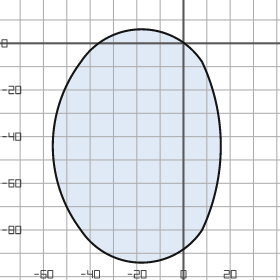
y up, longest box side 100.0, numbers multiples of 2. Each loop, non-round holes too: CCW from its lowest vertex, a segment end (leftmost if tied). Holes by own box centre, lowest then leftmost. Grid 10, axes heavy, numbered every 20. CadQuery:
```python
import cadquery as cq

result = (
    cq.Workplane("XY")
    .moveTo(-44.0, -80.0)
    .threePointArc((-18.0, -94.0), (8.0, -80.0))
    .threePointArc((16.0, -44.0), (8.0, -8.0))
    .threePointArc((-18.0, 6.0), (-44.0, -8.0))
    .threePointArc((-56.0, -44.0), (-44.0, -80.0))
    .close()
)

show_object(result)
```